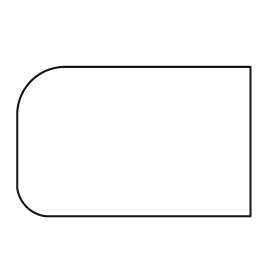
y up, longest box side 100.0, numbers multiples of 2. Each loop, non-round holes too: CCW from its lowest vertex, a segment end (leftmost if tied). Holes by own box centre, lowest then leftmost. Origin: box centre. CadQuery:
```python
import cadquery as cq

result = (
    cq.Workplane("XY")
    .moveTo(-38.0, -32.0)
    .lineTo(50.0, -32.0)
    .lineTo(50.0, 32.0)
    .lineTo(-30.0, 32.0)
    .threePointArc((-44.0, 26.0), (-50.0, 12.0))
    .lineTo(-50.0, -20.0)
    .threePointArc((-46.0, -28.0), (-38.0, -32.0))
    .close()
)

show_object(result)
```